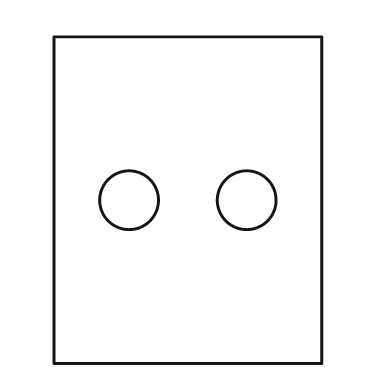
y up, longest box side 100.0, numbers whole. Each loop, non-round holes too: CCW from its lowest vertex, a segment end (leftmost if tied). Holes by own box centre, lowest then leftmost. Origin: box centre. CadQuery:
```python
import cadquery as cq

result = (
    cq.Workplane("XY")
    .moveTo(-41.0, -50.0)
    .lineTo(41.0, -50.0)
    .lineTo(41.0, 50.0)
    .lineTo(-41.0, 50.0)
    .close()
    .moveTo(-18.0, 0.0)
    .circle(9.0)
    .moveTo(18.0, 0.0)
    .circle(9.0)
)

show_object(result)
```